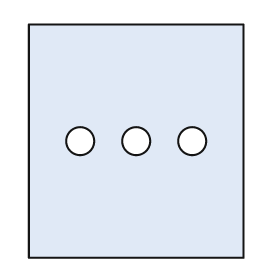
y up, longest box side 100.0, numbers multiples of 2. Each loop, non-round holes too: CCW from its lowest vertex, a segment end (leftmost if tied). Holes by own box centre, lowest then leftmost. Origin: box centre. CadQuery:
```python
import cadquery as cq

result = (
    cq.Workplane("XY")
    .moveTo(-46.0, -50.0)
    .lineTo(46.0, -50.0)
    .lineTo(46.0, 50.0)
    .lineTo(-46.0, 50.0)
    .close()
    .moveTo(-24.0, 0.0)
    .circle(6.0)
    .moveTo(0.0, 0.0)
    .circle(6.0)
    .moveTo(24.0, 0.0)
    .circle(6.0)
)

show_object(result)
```